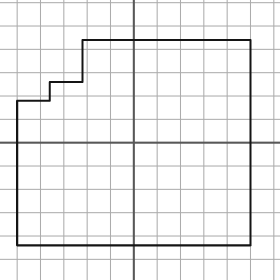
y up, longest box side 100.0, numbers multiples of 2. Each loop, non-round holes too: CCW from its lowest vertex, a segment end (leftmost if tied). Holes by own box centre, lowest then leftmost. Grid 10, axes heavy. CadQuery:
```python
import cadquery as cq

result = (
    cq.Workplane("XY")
    .moveTo(-50.0, -44.0)
    .lineTo(50.0, -44.0)
    .lineTo(50.0, 44.0)
    .lineTo(-22.0, 44.0)
    .lineTo(-22.0, 26.0)
    .lineTo(-36.0, 26.0)
    .lineTo(-36.0, 18.0)
    .lineTo(-50.0, 18.0)
    .close()
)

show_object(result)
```